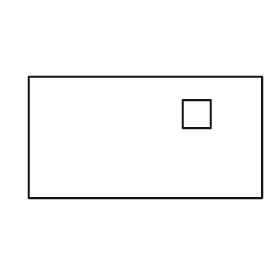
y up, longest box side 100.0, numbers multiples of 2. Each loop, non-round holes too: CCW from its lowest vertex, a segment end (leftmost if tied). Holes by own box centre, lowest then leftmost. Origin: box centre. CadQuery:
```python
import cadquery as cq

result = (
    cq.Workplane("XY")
    .moveTo(-50.0, -26.0)
    .lineTo(50.0, -26.0)
    .lineTo(50.0, 26.0)
    .lineTo(-50.0, 26.0)
    .close()
    .moveTo(16.0, 4.0)
    .lineTo(28.0, 4.0)
    .lineTo(28.0, 16.0)
    .lineTo(16.0, 16.0)
    .close()
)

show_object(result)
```